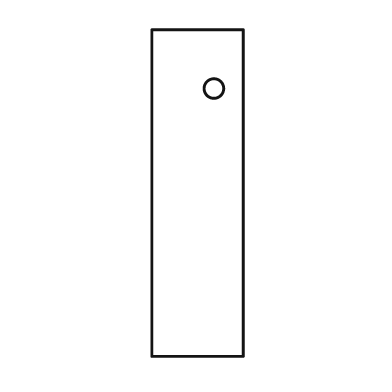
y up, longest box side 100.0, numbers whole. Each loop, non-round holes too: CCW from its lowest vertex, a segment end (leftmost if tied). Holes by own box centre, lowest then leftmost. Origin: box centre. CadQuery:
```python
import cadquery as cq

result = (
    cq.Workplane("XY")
    .moveTo(-14.0, -50.0)
    .lineTo(14.0, -50.0)
    .lineTo(14.0, 50.0)
    .lineTo(-14.0, 50.0)
    .close()
    .moveTo(5.0, 32.0)
    .circle(3.0)
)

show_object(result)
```